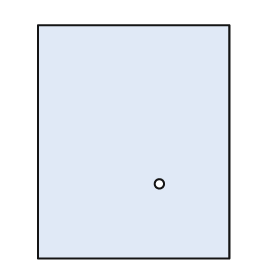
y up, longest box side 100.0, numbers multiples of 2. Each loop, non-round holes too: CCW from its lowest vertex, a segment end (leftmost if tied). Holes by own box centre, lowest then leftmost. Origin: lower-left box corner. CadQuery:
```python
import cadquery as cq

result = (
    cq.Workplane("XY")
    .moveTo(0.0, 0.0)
    .lineTo(82.0, 0.0)
    .lineTo(82.0, 100.0)
    .lineTo(0.0, 100.0)
    .close()
    .moveTo(52.0, 32.0)
    .circle(2.0)
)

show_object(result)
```